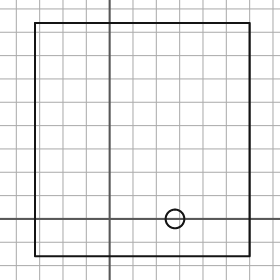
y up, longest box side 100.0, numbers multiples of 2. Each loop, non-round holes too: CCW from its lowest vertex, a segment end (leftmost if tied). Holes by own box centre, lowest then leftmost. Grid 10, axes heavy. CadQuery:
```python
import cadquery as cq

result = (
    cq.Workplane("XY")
    .moveTo(-32.0, -16.0)
    .lineTo(60.0, -16.0)
    .lineTo(60.0, 84.0)
    .lineTo(-32.0, 84.0)
    .close()
    .moveTo(28.0, 0.0)
    .circle(4.0)
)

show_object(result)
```